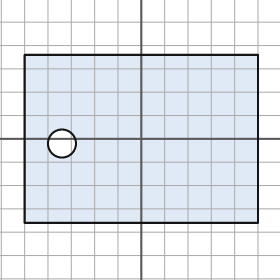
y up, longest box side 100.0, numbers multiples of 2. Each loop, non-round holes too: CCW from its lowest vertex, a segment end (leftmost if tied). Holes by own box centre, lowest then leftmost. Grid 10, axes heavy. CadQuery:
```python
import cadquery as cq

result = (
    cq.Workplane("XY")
    .moveTo(-50.0, -36.0)
    .lineTo(50.0, -36.0)
    .lineTo(50.0, 36.0)
    .lineTo(-50.0, 36.0)
    .close()
    .moveTo(-34.0, -2.0)
    .circle(6.0)
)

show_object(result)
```